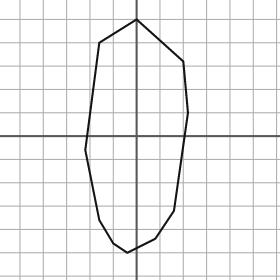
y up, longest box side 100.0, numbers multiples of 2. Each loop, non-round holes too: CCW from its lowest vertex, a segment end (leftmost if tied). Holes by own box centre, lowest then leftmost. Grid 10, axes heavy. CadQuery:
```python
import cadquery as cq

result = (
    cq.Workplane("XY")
    .moveTo(-4.0, -50.0)
    .lineTo(8.0, -44.0)
    .lineTo(16.0, -32.0)
    .lineTo(22.0, 10.0)
    .lineTo(20.0, 32.0)
    .lineTo(0.0, 50.0)
    .lineTo(-16.0, 40.0)
    .lineTo(-22.0, -6.0)
    .lineTo(-16.0, -36.0)
    .lineTo(-10.0, -46.0)
    .close()
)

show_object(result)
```